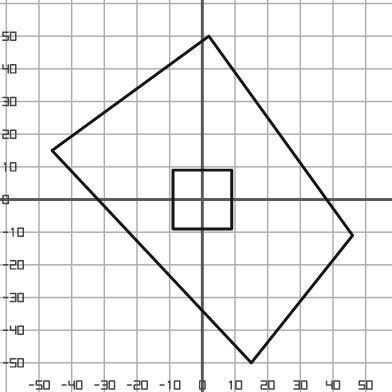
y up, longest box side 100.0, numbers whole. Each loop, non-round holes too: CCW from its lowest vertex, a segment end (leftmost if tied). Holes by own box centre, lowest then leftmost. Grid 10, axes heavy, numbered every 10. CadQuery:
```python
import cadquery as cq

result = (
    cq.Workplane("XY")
    .moveTo(15.0, -50.0)
    .lineTo(46.0, -11.0)
    .lineTo(2.0, 50.0)
    .lineTo(-46.0, 15.0)
    .close()
    .moveTo(-9.0, -9.0)
    .lineTo(9.0, -9.0)
    .lineTo(9.0, 9.0)
    .lineTo(-9.0, 9.0)
    .close()
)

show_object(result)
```